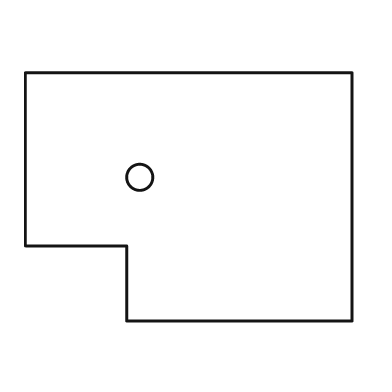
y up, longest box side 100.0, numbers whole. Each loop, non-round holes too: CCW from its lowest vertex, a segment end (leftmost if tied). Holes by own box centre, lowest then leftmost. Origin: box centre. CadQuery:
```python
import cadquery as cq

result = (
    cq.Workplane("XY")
    .moveTo(-19.0, -38.0)
    .lineTo(50.0, -38.0)
    .lineTo(50.0, 38.0)
    .lineTo(-50.0, 38.0)
    .lineTo(-50.0, -15.0)
    .lineTo(-19.0, -15.0)
    .close()
    .moveTo(-15.0, 6.0)
    .circle(4.0)
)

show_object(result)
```